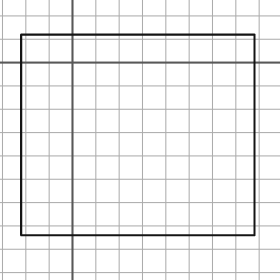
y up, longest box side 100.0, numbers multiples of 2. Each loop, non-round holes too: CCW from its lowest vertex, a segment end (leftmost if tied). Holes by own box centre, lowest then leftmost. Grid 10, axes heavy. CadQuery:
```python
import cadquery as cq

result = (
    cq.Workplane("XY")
    .moveTo(-22.0, -74.0)
    .lineTo(78.0, -74.0)
    .lineTo(78.0, 12.0)
    .lineTo(-22.0, 12.0)
    .close()
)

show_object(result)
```